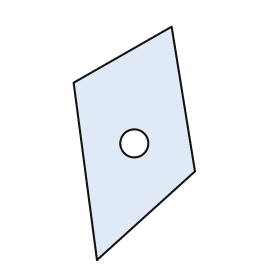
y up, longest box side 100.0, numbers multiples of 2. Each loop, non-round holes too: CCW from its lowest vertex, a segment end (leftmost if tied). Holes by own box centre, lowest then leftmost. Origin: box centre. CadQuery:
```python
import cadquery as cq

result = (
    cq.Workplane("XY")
    .moveTo(-16.0, -50.0)
    .lineTo(26.0, -12.0)
    .lineTo(16.0, 50.0)
    .lineTo(-26.0, 26.0)
    .close()
    .moveTo(0.0, 0.0)
    .circle(6.0)
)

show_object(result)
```